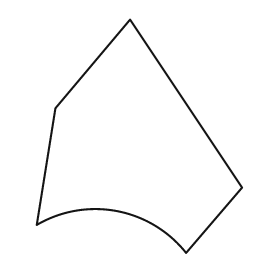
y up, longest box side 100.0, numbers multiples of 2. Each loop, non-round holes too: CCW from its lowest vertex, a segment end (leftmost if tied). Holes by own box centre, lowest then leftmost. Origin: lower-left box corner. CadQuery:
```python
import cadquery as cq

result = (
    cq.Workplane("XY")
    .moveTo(64.0, 0.0)
    .lineTo(88.0, 28.0)
    .lineTo(40.0, 100.0)
    .lineTo(8.0, 62.0)
    .lineTo(0.0, 12.0)
    .threePointArc((34.0, 18.0), (64.0, 0.0))
    .close()
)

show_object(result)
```